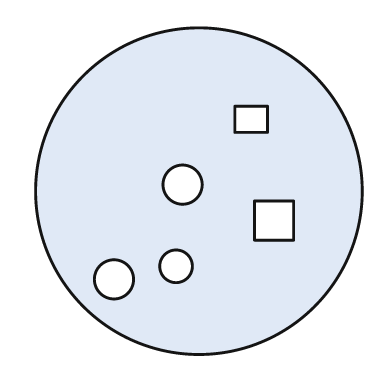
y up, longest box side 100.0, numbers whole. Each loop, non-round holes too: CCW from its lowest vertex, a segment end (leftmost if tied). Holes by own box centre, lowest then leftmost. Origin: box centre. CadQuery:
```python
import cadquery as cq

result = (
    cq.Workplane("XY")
    .moveTo(0.0, 0.0)
    .circle(50.0)
    .moveTo(-26.0, -27.0)
    .circle(6.0)
    .moveTo(-7.0, -23.0)
    .circle(5.0)
    .moveTo(17.0, -15.0)
    .lineTo(29.0, -15.0)
    .lineTo(29.0, -3.0)
    .lineTo(17.0, -3.0)
    .close()
    .moveTo(-5.0, 2.0)
    .circle(6.0)
    .moveTo(11.0, 18.0)
    .lineTo(21.0, 18.0)
    .lineTo(21.0, 26.0)
    .lineTo(11.0, 26.0)
    .close()
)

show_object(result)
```